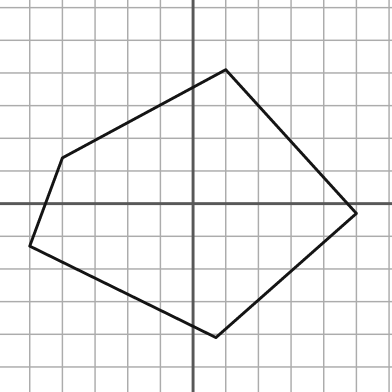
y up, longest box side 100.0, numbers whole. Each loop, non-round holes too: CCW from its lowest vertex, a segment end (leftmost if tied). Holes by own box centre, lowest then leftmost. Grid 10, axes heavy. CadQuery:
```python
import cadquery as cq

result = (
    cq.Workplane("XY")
    .moveTo(7.0, -41.0)
    .lineTo(50.0, -3.0)
    .lineTo(10.0, 41.0)
    .lineTo(-40.0, 14.0)
    .lineTo(-50.0, -13.0)
    .close()
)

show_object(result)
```